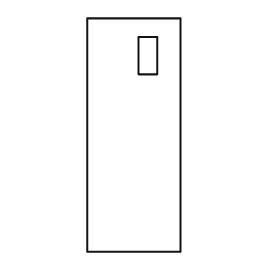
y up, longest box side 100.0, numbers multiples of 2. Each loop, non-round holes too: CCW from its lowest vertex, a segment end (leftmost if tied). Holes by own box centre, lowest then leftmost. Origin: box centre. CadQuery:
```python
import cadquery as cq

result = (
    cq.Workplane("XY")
    .moveTo(-20.0, -50.0)
    .lineTo(20.0, -50.0)
    .lineTo(20.0, 50.0)
    .lineTo(-20.0, 50.0)
    .close()
    .moveTo(2.0, 26.0)
    .lineTo(10.0, 26.0)
    .lineTo(10.0, 42.0)
    .lineTo(2.0, 42.0)
    .close()
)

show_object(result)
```